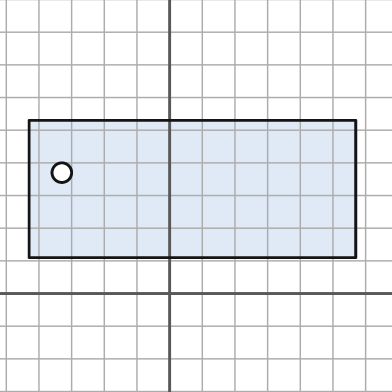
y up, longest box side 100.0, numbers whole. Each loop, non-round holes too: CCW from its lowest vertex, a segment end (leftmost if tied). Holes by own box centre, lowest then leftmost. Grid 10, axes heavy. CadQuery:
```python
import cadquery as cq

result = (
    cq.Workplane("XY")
    .moveTo(-43.0, 11.0)
    .lineTo(57.0, 11.0)
    .lineTo(57.0, 53.0)
    .lineTo(-43.0, 53.0)
    .close()
    .moveTo(-33.0, 37.0)
    .circle(3.0)
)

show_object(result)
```